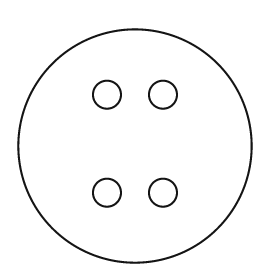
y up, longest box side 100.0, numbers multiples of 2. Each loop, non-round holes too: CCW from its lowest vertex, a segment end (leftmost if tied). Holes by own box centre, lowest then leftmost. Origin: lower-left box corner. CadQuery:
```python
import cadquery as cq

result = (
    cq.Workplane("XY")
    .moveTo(50.0, 50.0)
    .circle(50.0)
    .moveTo(38.0, 30.0)
    .circle(6.0)
    .moveTo(62.0, 30.0)
    .circle(6.0)
    .moveTo(38.0, 72.0)
    .circle(6.0)
    .moveTo(62.0, 72.0)
    .circle(6.0)
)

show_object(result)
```